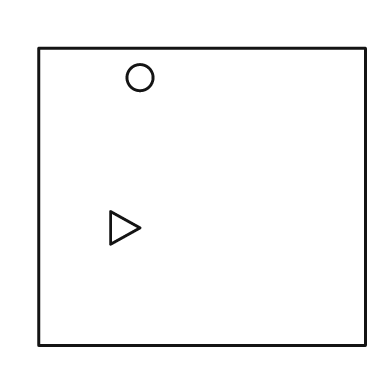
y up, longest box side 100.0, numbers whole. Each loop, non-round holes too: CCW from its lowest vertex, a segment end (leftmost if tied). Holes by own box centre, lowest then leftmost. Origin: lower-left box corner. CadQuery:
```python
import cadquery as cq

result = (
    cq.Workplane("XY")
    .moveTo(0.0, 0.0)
    .lineTo(100.0, 0.0)
    .lineTo(100.0, 91.0)
    .lineTo(0.0, 91.0)
    .close()
    .moveTo(22.0, 31.0)
    .lineTo(31.0, 36.0)
    .lineTo(22.0, 41.0)
    .close()
    .moveTo(31.0, 82.0)
    .circle(4.0)
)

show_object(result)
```